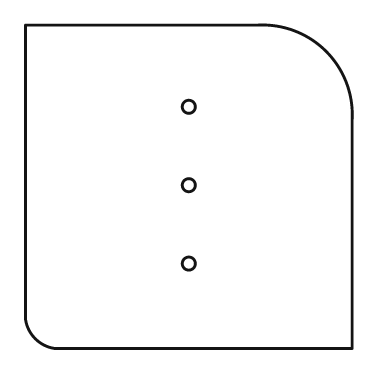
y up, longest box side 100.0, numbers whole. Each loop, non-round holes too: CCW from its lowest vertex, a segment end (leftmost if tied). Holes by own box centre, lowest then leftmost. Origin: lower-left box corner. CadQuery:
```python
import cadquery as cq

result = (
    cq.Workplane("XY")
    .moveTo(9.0, 0.0)
    .lineTo(100.0, 0.0)
    .lineTo(100.0, 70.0)
    .threePointArc((92.0, 91.0), (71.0, 99.0))
    .lineTo(0.0, 99.0)
    .lineTo(0.0, 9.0)
    .threePointArc((3.0, 3.0), (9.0, 0.0))
    .close()
    .moveTo(50.0, 26.0)
    .circle(2.0)
    .moveTo(50.0, 50.0)
    .circle(2.0)
    .moveTo(50.0, 74.0)
    .circle(2.0)
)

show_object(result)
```